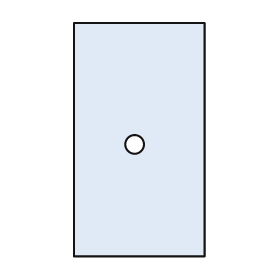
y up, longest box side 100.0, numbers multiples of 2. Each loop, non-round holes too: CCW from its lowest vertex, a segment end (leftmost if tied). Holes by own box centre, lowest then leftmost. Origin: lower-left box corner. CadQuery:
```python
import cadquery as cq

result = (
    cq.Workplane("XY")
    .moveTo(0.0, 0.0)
    .lineTo(56.0, 0.0)
    .lineTo(56.0, 100.0)
    .lineTo(0.0, 100.0)
    .close()
    .moveTo(26.0, 48.0)
    .circle(4.0)
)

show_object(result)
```